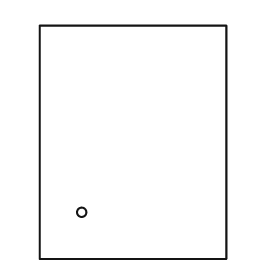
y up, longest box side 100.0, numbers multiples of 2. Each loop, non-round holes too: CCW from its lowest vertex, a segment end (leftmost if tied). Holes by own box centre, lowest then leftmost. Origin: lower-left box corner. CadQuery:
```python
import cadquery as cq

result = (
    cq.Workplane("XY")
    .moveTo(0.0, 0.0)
    .lineTo(80.0, 0.0)
    .lineTo(80.0, 100.0)
    .lineTo(0.0, 100.0)
    .close()
    .moveTo(18.0, 20.0)
    .circle(2.0)
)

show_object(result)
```